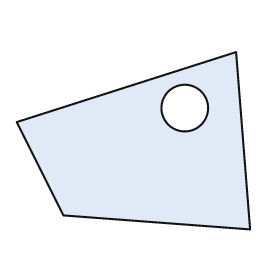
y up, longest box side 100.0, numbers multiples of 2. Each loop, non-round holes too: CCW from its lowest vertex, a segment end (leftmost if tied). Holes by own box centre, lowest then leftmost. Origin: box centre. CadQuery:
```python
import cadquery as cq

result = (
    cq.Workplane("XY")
    .moveTo(50.0, -38.0)
    .lineTo(44.0, 38.0)
    .lineTo(-50.0, 8.0)
    .lineTo(-30.0, -32.0)
    .close()
    .moveTo(22.0, 14.0)
    .circle(10.0)
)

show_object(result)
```